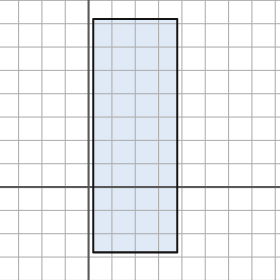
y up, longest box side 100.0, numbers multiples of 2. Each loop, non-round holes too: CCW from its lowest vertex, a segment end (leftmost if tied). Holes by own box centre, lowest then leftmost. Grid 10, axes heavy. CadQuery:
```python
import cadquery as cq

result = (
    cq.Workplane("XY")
    .moveTo(2.0, -28.0)
    .lineTo(38.0, -28.0)
    .lineTo(38.0, 72.0)
    .lineTo(2.0, 72.0)
    .close()
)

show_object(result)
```